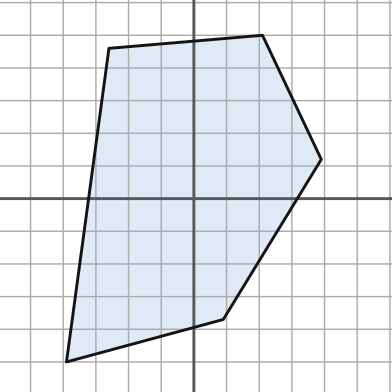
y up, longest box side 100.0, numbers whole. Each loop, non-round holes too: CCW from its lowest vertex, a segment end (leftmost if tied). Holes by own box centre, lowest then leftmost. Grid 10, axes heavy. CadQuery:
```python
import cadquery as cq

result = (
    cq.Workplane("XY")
    .moveTo(-39.0, -50.0)
    .lineTo(9.0, -37.0)
    .lineTo(39.0, 12.0)
    .lineTo(21.0, 50.0)
    .lineTo(-26.0, 46.0)
    .close()
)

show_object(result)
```